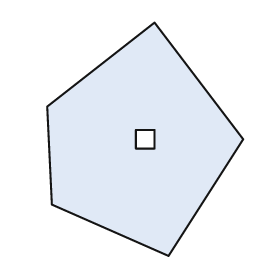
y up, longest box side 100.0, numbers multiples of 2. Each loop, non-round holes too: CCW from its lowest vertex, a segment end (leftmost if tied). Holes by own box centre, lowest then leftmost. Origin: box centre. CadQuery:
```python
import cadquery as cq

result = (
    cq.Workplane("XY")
    .moveTo(10.0, -50.0)
    .lineTo(42.0, 0.0)
    .lineTo(4.0, 50.0)
    .lineTo(-42.0, 14.0)
    .lineTo(-40.0, -28.0)
    .close()
    .moveTo(-4.0, -4.0)
    .lineTo(4.0, -4.0)
    .lineTo(4.0, 4.0)
    .lineTo(-4.0, 4.0)
    .close()
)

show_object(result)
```